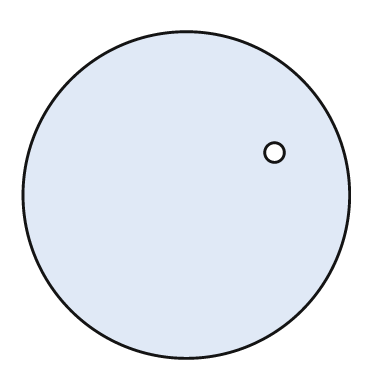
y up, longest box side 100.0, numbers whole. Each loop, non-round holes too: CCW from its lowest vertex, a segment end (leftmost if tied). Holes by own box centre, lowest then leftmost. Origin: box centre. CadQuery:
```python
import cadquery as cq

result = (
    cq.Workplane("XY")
    .moveTo(0.0, 0.0)
    .circle(50.0)
    .moveTo(27.0, 13.0)
    .circle(3.0)
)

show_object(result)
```